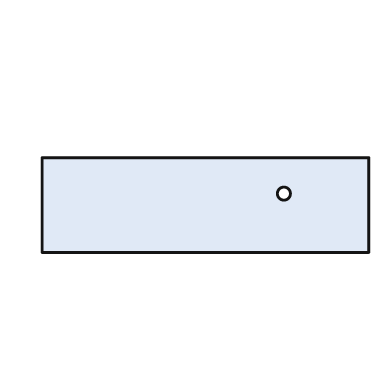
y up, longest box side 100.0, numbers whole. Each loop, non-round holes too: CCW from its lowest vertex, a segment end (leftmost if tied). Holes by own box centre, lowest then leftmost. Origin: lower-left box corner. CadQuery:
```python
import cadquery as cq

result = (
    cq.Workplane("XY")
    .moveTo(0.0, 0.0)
    .lineTo(100.0, 0.0)
    .lineTo(100.0, 29.0)
    .lineTo(0.0, 29.0)
    .close()
    .moveTo(74.0, 18.0)
    .circle(2.0)
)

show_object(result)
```